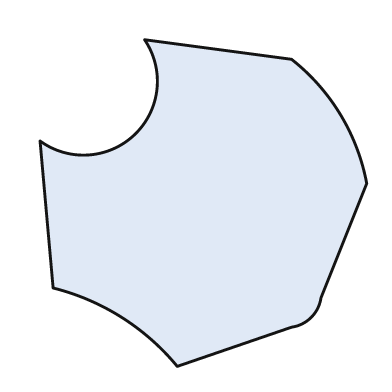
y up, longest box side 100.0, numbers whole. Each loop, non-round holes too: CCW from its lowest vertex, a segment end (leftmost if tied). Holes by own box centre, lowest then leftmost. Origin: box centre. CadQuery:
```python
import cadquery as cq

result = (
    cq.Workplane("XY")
    .moveTo(-8.0, -50.0)
    .lineTo(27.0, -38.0)
    .threePointArc((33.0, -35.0), (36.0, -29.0))
    .lineTo(50.0, 6.0)
    .threePointArc((42.0, 27.0), (27.0, 44.0))
    .lineTo(-18.0, 50.0)
    .threePointArc((-21.0, 21.0), (-50.0, 19.0))
    .lineTo(-46.0, -26.0)
    .threePointArc((-25.0, -35.0), (-8.0, -50.0))
    .close()
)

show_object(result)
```